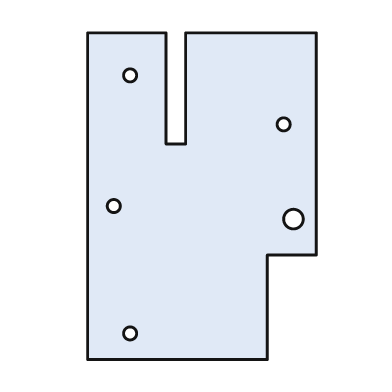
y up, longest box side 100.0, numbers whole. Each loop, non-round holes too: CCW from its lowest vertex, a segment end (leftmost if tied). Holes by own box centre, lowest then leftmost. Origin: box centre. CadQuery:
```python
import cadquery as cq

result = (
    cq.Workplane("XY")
    .moveTo(-35.0, -50.0)
    .lineTo(20.0, -50.0)
    .lineTo(20.0, -18.0)
    .lineTo(35.0, -18.0)
    .lineTo(35.0, 50.0)
    .lineTo(-5.0, 50.0)
    .lineTo(-5.0, 16.0)
    .lineTo(-11.0, 16.0)
    .lineTo(-11.0, 50.0)
    .lineTo(-35.0, 50.0)
    .close()
    .moveTo(-22.0, -42.0)
    .circle(2.0)
    .moveTo(28.0, -7.0)
    .circle(3.0)
    .moveTo(-27.0, -3.0)
    .circle(2.0)
    .moveTo(25.0, 22.0)
    .circle(2.0)
    .moveTo(-22.0, 37.0)
    .circle(2.0)
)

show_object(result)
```